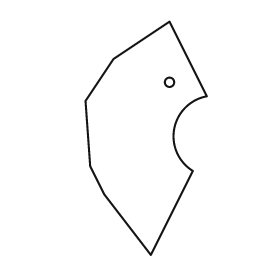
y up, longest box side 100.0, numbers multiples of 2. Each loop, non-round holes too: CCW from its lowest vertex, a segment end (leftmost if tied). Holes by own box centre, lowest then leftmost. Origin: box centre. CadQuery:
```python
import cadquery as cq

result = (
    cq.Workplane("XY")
    .moveTo(2.0, -50.0)
    .lineTo(20.0, -14.0)
    .threePointArc((12.0, 4.0), (26.0, 18.0))
    .lineTo(10.0, 50.0)
    .lineTo(-14.0, 34.0)
    .lineTo(-26.0, 16.0)
    .lineTo(-24.0, -12.0)
    .lineTo(-18.0, -24.0)
    .close()
    .moveTo(10.0, 24.0)
    .circle(2.0)
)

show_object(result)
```